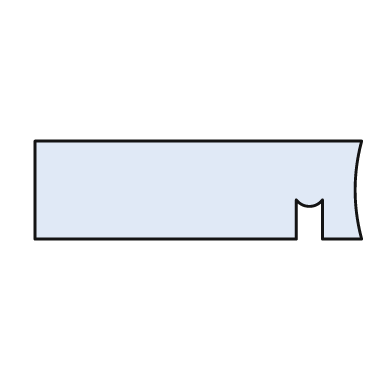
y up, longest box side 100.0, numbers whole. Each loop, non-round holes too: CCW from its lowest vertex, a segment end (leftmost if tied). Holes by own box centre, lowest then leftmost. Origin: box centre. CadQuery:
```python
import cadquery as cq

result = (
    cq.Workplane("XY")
    .moveTo(-50.0, -15.0)
    .lineTo(30.0, -15.0)
    .lineTo(30.0, -3.0)
    .threePointArc((34.0, -5.0), (38.0, -3.0))
    .lineTo(38.0, -15.0)
    .lineTo(50.0, -15.0)
    .threePointArc((48.0, 0.0), (50.0, 15.0))
    .lineTo(-50.0, 15.0)
    .close()
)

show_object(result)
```